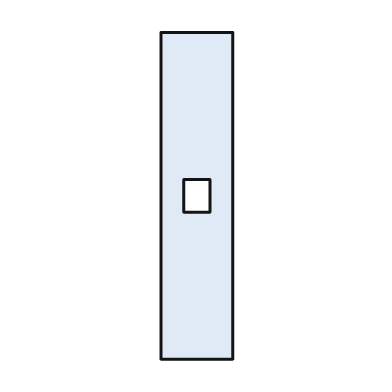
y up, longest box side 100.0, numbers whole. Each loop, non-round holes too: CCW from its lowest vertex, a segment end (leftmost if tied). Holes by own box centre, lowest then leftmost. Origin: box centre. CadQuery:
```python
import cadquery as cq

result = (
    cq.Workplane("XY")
    .moveTo(-11.0, -50.0)
    .lineTo(11.0, -50.0)
    .lineTo(11.0, 50.0)
    .lineTo(-11.0, 50.0)
    .close()
    .moveTo(-4.0, -5.0)
    .lineTo(4.0, -5.0)
    .lineTo(4.0, 5.0)
    .lineTo(-4.0, 5.0)
    .close()
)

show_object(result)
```